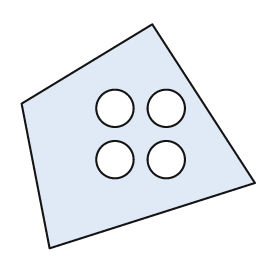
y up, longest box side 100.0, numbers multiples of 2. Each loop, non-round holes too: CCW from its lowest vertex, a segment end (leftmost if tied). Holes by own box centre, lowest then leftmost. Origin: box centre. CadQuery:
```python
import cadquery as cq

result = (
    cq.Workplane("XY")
    .moveTo(-38.0, -48.0)
    .lineTo(50.0, -20.0)
    .lineTo(6.0, 48.0)
    .lineTo(-50.0, 14.0)
    .close()
    .moveTo(-10.0, -10.0)
    .circle(8.0)
    .moveTo(12.0, -10.0)
    .circle(8.0)
    .moveTo(-10.0, 12.0)
    .circle(8.0)
    .moveTo(12.0, 12.0)
    .circle(8.0)
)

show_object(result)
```